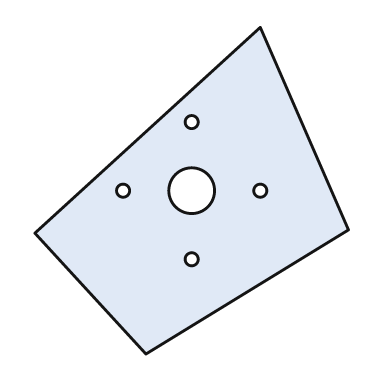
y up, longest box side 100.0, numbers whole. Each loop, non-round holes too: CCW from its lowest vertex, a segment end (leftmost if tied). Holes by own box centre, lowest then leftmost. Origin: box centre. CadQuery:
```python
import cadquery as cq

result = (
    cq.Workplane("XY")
    .moveTo(-14.0, -50.0)
    .lineTo(48.0, -12.0)
    .lineTo(21.0, 50.0)
    .lineTo(-48.0, -13.0)
    .close()
    .moveTo(0.0, -21.0)
    .circle(2.0)
    .moveTo(-21.0, 0.0)
    .circle(2.0)
    .moveTo(0.0, 0.0)
    .circle(7.0)
    .moveTo(21.0, 0.0)
    .circle(2.0)
    .moveTo(0.0, 21.0)
    .circle(2.0)
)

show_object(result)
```